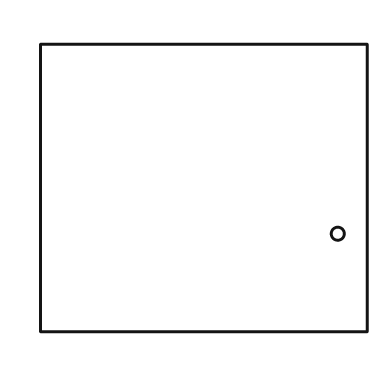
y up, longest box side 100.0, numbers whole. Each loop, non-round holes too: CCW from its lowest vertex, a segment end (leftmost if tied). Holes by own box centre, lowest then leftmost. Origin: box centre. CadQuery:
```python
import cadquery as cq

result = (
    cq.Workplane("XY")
    .moveTo(-50.0, -44.0)
    .lineTo(50.0, -44.0)
    .lineTo(50.0, 44.0)
    .lineTo(-50.0, 44.0)
    .close()
    .moveTo(41.0, -14.0)
    .circle(2.0)
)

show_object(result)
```